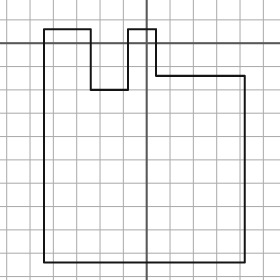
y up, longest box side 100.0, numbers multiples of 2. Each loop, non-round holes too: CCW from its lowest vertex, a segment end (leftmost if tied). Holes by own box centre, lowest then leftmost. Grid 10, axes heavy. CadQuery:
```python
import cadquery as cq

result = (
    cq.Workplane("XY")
    .moveTo(-44.0, -94.0)
    .lineTo(42.0, -94.0)
    .lineTo(42.0, -14.0)
    .lineTo(4.0, -14.0)
    .lineTo(4.0, 6.0)
    .lineTo(-8.0, 6.0)
    .lineTo(-8.0, -20.0)
    .lineTo(-24.0, -20.0)
    .lineTo(-24.0, 6.0)
    .lineTo(-44.0, 6.0)
    .close()
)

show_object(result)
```